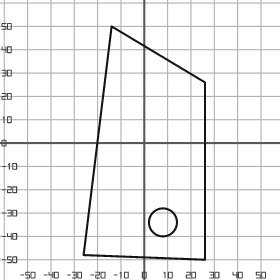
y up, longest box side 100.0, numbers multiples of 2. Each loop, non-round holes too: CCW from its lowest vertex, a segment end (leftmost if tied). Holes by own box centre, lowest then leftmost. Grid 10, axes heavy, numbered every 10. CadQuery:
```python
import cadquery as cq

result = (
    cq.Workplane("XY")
    .moveTo(26.0, -50.0)
    .lineTo(26.0, 26.0)
    .lineTo(-14.0, 50.0)
    .lineTo(-26.0, -48.0)
    .close()
    .moveTo(8.0, -34.0)
    .circle(6.0)
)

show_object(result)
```